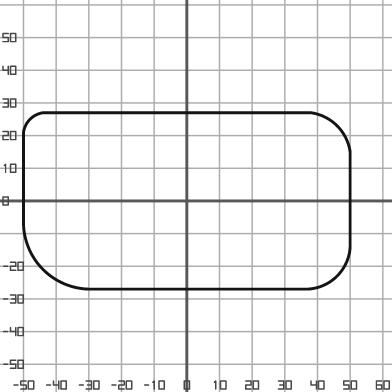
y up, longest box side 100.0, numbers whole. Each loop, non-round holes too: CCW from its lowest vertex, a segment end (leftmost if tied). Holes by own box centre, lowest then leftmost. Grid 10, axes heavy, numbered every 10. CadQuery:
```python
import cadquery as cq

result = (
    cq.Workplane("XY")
    .moveTo(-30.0, -27.0)
    .lineTo(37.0, -27.0)
    .threePointArc((46.0, -23.0), (50.0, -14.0))
    .lineTo(50.0, 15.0)
    .threePointArc((46.0, 23.0), (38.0, 27.0))
    .lineTo(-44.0, 27.0)
    .threePointArc((-48.0, 25.0), (-50.0, 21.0))
    .lineTo(-50.0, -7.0)
    .threePointArc((-44.0, -21.0), (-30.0, -27.0))
    .close()
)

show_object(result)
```